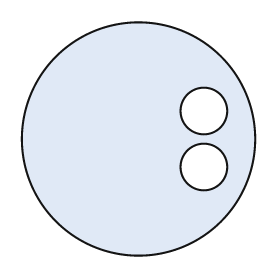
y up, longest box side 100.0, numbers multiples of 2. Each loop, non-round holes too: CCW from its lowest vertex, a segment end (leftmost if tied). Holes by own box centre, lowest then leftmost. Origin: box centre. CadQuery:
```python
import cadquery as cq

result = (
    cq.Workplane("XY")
    .moveTo(0.0, 0.0)
    .circle(50.0)
    .moveTo(28.0, -12.0)
    .circle(10.0)
    .moveTo(28.0, 12.0)
    .circle(10.0)
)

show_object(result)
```